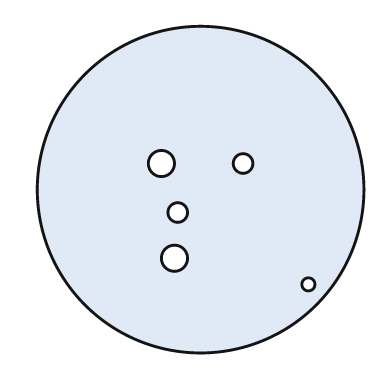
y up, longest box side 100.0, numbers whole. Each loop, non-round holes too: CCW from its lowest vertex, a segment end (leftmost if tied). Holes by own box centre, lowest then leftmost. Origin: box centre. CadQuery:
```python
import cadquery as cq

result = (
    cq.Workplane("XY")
    .moveTo(0.0, 0.0)
    .circle(50.0)
    .moveTo(33.0, -29.0)
    .circle(2.0)
    .moveTo(-8.0, -21.0)
    .circle(4.0)
    .moveTo(-7.0, -7.0)
    .circle(3.0)
    .moveTo(-12.0, 8.0)
    .circle(4.0)
    .moveTo(13.0, 8.0)
    .circle(3.0)
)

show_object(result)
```